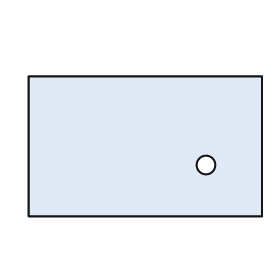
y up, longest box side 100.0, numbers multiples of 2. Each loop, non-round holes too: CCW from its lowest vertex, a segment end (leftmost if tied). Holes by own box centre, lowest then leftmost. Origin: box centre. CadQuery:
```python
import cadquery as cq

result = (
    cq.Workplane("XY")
    .moveTo(-50.0, -30.0)
    .lineTo(50.0, -30.0)
    .lineTo(50.0, 30.0)
    .lineTo(-50.0, 30.0)
    .close()
    .moveTo(26.0, -8.0)
    .circle(4.0)
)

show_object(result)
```